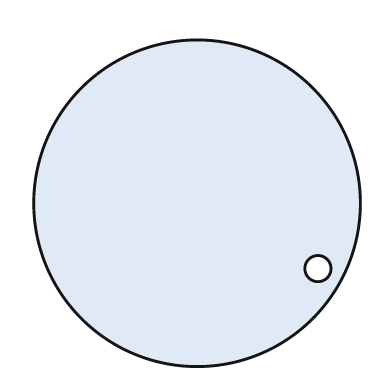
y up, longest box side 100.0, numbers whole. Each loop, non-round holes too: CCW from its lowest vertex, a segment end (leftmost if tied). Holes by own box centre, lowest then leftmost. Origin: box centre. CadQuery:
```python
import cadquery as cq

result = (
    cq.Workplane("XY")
    .moveTo(0.0, 0.0)
    .circle(50.0)
    .moveTo(37.0, -20.0)
    .circle(4.0)
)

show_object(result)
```